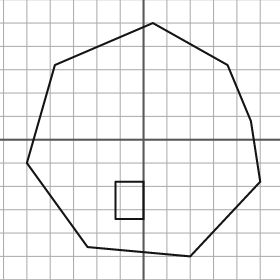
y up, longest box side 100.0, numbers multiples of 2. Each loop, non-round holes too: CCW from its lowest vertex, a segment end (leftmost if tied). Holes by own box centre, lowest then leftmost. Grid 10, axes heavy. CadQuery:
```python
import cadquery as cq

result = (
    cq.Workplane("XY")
    .moveTo(20.0, -50.0)
    .lineTo(50.0, -18.0)
    .lineTo(46.0, 8.0)
    .lineTo(36.0, 32.0)
    .lineTo(4.0, 50.0)
    .lineTo(-38.0, 32.0)
    .lineTo(-50.0, -10.0)
    .lineTo(-24.0, -46.0)
    .close()
    .moveTo(-12.0, -34.0)
    .lineTo(0.0, -34.0)
    .lineTo(0.0, -18.0)
    .lineTo(-12.0, -18.0)
    .close()
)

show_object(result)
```